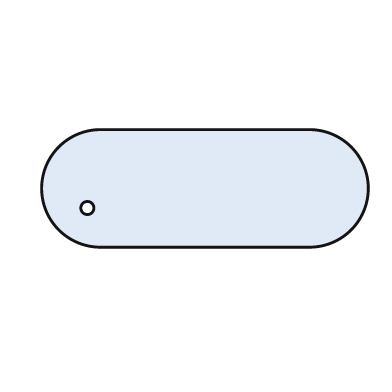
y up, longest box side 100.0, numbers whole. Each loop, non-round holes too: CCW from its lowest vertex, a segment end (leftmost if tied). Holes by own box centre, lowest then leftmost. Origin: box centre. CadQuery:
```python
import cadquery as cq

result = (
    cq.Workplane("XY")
    .moveTo(-32.0, -18.0)
    .lineTo(32.0, -18.0)
    .threePointArc((50.0, 0.0), (32.0, 18.0))
    .lineTo(-32.0, 18.0)
    .threePointArc((-50.0, 0.0), (-32.0, -18.0))
    .close()
    .moveTo(-36.0, -6.0)
    .circle(2.0)
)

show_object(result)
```